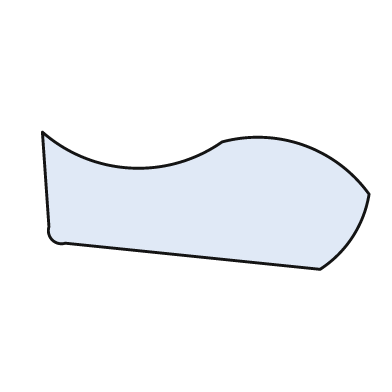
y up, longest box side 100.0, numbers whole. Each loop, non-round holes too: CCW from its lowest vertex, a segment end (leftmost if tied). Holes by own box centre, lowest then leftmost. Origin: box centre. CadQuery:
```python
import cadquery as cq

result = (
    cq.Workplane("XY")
    .moveTo(35.0, -21.0)
    .threePointArc((45.0, -11.0), (50.0, 2.0))
    .threePointArc((30.0, 17.0), (5.0, 18.0))
    .threePointArc((-23.0, 10.0), (-50.0, 21.0))
    .lineTo(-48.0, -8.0)
    .threePointArc((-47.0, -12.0), (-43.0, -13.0))
    .close()
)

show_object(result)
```